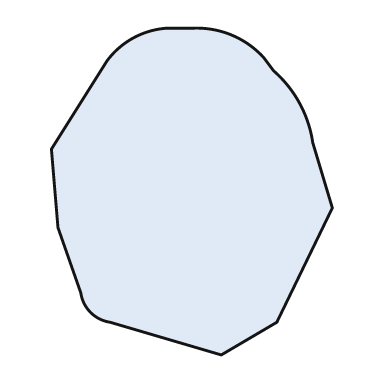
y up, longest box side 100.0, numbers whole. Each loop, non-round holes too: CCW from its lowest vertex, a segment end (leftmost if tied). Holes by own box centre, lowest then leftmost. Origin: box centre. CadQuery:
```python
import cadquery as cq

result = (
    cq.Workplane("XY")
    .moveTo(9.0, -50.0)
    .lineTo(26.0, -40.0)
    .lineTo(43.0, -5.0)
    .lineTo(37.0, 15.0)
    .threePointArc((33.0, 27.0), (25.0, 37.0))
    .lineTo(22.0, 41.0)
    .threePointArc((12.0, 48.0), (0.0, 50.0))
    .lineTo(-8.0, 50.0)
    .threePointArc((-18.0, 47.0), (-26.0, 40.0))
    .lineTo(-43.0, 13.0)
    .lineTo(-41.0, -11.0)
    .lineTo(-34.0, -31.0)
    .threePointArc((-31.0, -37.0), (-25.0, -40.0))
    .close()
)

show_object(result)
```